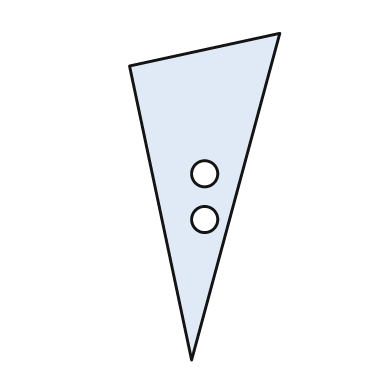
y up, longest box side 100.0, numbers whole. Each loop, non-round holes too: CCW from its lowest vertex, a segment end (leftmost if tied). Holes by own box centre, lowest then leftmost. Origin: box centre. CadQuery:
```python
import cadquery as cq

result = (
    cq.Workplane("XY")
    .moveTo(-4.0, -50.0)
    .lineTo(23.0, 50.0)
    .lineTo(-23.0, 40.0)
    .close()
    .moveTo(0.0, -7.0)
    .circle(4.0)
    .moveTo(0.0, 7.0)
    .circle(4.0)
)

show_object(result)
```